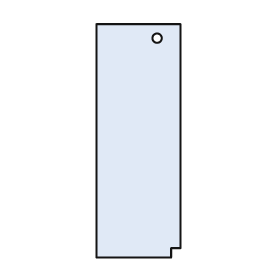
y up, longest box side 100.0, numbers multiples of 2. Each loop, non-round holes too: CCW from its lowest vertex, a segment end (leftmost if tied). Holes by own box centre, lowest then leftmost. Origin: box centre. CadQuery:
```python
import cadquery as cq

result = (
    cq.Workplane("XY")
    .moveTo(-18.0, -50.0)
    .lineTo(14.0, -50.0)
    .lineTo(14.0, -46.0)
    .lineTo(18.0, -46.0)
    .lineTo(18.0, 50.0)
    .lineTo(-18.0, 50.0)
    .close()
    .moveTo(8.0, 44.0)
    .circle(2.0)
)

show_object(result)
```